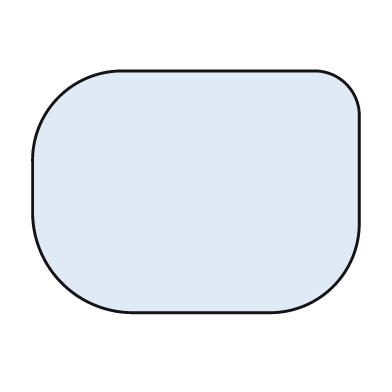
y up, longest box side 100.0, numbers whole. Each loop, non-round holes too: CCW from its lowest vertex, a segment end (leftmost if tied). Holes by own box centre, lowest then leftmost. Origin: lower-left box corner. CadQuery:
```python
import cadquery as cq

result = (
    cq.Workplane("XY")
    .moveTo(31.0, 0.0)
    .lineTo(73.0, 0.0)
    .threePointArc((92.0, 8.0), (100.0, 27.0))
    .lineTo(100.0, 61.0)
    .threePointArc((96.0, 70.0), (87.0, 74.0))
    .lineTo(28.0, 74.0)
    .threePointArc((8.0, 66.0), (0.0, 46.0))
    .lineTo(0.0, 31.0)
    .threePointArc((9.0, 9.0), (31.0, 0.0))
    .close()
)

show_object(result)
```